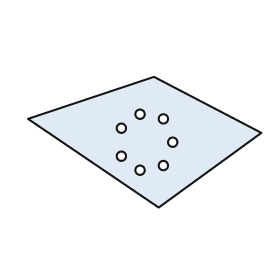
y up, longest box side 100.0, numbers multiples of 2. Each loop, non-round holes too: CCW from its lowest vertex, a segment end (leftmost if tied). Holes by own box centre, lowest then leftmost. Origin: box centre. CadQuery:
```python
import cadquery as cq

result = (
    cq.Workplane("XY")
    .moveTo(6.0, -28.0)
    .lineTo(50.0, 4.0)
    .lineTo(4.0, 28.0)
    .lineTo(-50.0, 10.0)
    .close()
    .moveTo(-2.0, -12.0)
    .circle(2.0)
    .moveTo(8.0, -10.0)
    .circle(2.0)
    .moveTo(-10.0, -6.0)
    .circle(2.0)
    .moveTo(12.0, 0.0)
    .circle(2.0)
    .moveTo(-10.0, 6.0)
    .circle(2.0)
    .moveTo(8.0, 10.0)
    .circle(2.0)
    .moveTo(-2.0, 12.0)
    .circle(2.0)
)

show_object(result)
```